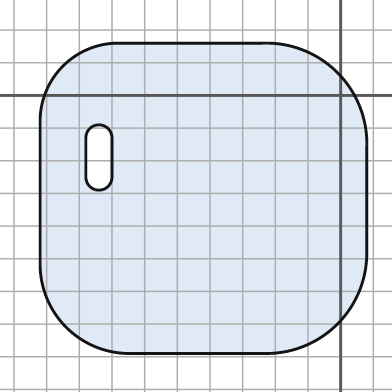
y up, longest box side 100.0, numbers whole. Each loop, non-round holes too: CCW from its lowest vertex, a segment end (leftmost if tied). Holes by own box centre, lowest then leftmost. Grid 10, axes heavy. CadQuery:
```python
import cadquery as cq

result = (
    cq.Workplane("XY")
    .moveTo(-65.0, -79.0)
    .lineTo(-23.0, -79.0)
    .threePointArc((-1.0, -70.0), (8.0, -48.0))
    .lineTo(8.0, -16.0)
    .threePointArc((-1.0, 7.0), (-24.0, 16.0))
    .lineTo(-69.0, 16.0)
    .threePointArc((-85.0, 9.0), (-92.0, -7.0))
    .lineTo(-92.0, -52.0)
    .threePointArc((-84.0, -71.0), (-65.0, -79.0))
    .close()
    .moveTo(-78.0, -25.0)
    .threePointArc((-74.0, -29.0), (-70.0, -25.0))
    .lineTo(-70.0, -13.0)
    .threePointArc((-74.0, -9.0), (-78.0, -13.0))
    .close()
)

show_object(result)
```